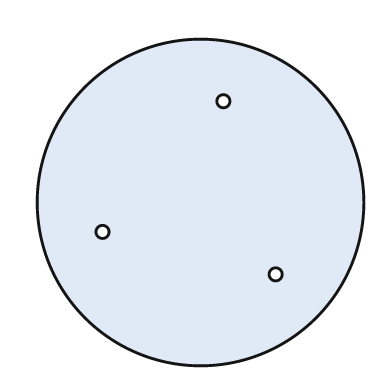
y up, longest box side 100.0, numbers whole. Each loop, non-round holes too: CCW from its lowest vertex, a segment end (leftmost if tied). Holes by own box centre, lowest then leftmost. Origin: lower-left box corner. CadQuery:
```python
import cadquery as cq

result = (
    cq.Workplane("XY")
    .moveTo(50.0, 50.0)
    .circle(50.0)
    .moveTo(73.0, 28.0)
    .circle(2.0)
    .moveTo(20.0, 41.0)
    .circle(2.0)
    .moveTo(57.0, 81.0)
    .circle(2.0)
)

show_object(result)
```